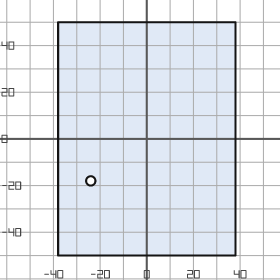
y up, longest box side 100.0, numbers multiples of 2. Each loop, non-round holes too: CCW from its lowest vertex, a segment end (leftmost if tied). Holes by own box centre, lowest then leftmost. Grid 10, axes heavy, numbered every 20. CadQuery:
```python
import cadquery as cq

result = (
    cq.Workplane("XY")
    .moveTo(-38.0, -50.0)
    .lineTo(38.0, -50.0)
    .lineTo(38.0, 50.0)
    .lineTo(-38.0, 50.0)
    .close()
    .moveTo(-24.0, -18.0)
    .circle(2.0)
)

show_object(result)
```